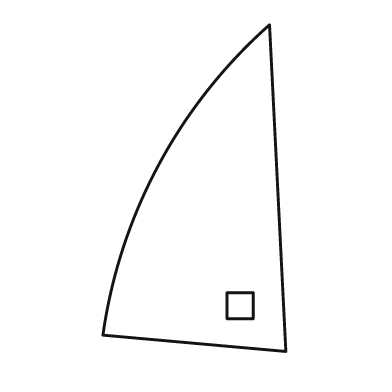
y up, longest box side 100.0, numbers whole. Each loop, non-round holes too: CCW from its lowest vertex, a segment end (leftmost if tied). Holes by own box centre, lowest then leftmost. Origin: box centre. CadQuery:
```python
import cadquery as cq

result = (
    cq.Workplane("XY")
    .moveTo(28.0, -50.0)
    .lineTo(23.0, 50.0)
    .threePointArc((-11.0, 7.0), (-28.0, -45.0))
    .close()
    .moveTo(10.0, -40.0)
    .lineTo(18.0, -40.0)
    .lineTo(18.0, -32.0)
    .lineTo(10.0, -32.0)
    .close()
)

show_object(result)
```